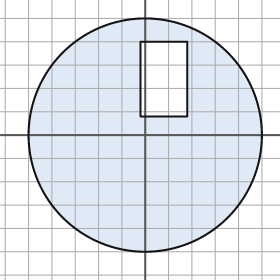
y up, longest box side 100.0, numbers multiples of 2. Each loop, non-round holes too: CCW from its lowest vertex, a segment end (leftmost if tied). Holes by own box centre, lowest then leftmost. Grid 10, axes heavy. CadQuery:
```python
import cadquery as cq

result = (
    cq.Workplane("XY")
    .moveTo(0.0, 0.0)
    .circle(50.0)
    .moveTo(-2.0, 8.0)
    .lineTo(18.0, 8.0)
    .lineTo(18.0, 40.0)
    .lineTo(-2.0, 40.0)
    .close()
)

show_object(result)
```